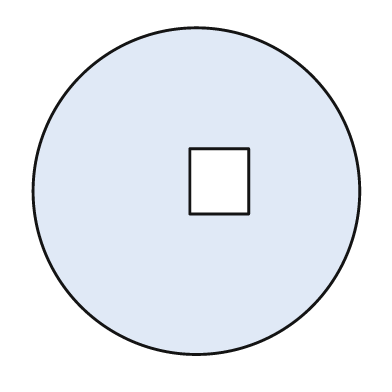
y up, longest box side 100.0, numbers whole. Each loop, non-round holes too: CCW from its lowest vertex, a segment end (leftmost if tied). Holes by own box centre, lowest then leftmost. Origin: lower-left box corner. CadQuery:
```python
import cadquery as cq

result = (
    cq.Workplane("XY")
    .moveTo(50.0, 50.0)
    .circle(50.0)
    .moveTo(48.0, 43.0)
    .lineTo(66.0, 43.0)
    .lineTo(66.0, 63.0)
    .lineTo(48.0, 63.0)
    .close()
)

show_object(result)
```